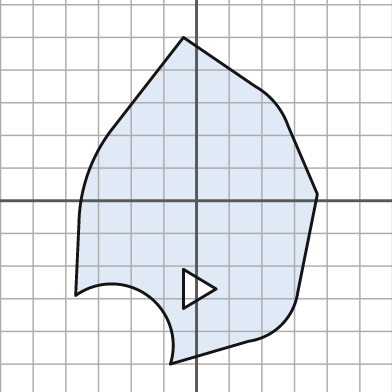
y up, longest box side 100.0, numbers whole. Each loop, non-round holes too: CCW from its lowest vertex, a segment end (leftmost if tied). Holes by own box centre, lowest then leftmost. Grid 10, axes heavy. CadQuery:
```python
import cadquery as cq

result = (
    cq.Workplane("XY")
    .moveTo(-8.0, -50.0)
    .lineTo(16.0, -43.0)
    .threePointArc((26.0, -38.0), (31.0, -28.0))
    .lineTo(37.0, 2.0)
    .lineTo(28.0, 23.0)
    .threePointArc((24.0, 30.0), (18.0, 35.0))
    .lineTo(-4.0, 50.0)
    .lineTo(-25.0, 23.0)
    .threePointArc((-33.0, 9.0), (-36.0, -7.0))
    .lineTo(-37.0, -29.0)
    .threePointArc((-15.0, -29.0), (-8.0, -50.0))
    .close()
    .moveTo(-4.0, -33.0)
    .lineTo(6.0, -27.0)
    .lineTo(-4.0, -21.0)
    .close()
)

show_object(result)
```